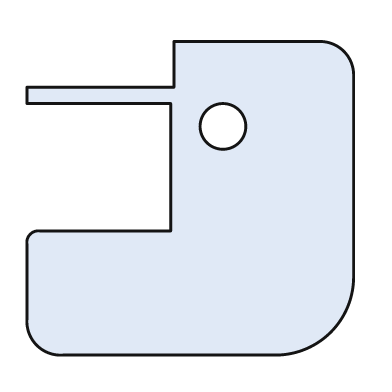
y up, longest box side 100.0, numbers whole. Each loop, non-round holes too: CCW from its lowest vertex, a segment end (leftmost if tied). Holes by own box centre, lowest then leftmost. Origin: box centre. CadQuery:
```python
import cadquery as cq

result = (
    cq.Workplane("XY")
    .moveTo(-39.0, -48.0)
    .lineTo(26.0, -48.0)
    .threePointArc((43.0, -41.0), (50.0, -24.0))
    .lineTo(50.0, 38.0)
    .threePointArc((47.0, 45.0), (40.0, 48.0))
    .lineTo(-5.0, 48.0)
    .lineTo(-5.0, 34.0)
    .lineTo(-50.0, 34.0)
    .lineTo(-50.0, 29.0)
    .lineTo(-6.0, 29.0)
    .lineTo(-6.0, -10.0)
    .lineTo(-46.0, -10.0)
    .threePointArc((-49.0, -11.0), (-50.0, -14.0))
    .lineTo(-50.0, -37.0)
    .threePointArc((-47.0, -45.0), (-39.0, -48.0))
    .close()
    .moveTo(10.0, 22.0)
    .circle(7.0)
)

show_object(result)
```